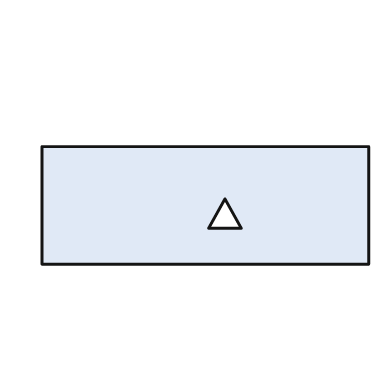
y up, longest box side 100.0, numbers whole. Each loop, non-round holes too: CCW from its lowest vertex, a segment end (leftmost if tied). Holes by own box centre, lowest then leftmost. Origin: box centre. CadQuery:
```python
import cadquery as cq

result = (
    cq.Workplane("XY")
    .moveTo(-50.0, -18.0)
    .lineTo(50.0, -18.0)
    .lineTo(50.0, 18.0)
    .lineTo(-50.0, 18.0)
    .close()
    .moveTo(1.0, -7.0)
    .lineTo(11.0, -7.0)
    .lineTo(6.0, 2.0)
    .close()
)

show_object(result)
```